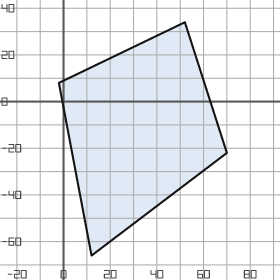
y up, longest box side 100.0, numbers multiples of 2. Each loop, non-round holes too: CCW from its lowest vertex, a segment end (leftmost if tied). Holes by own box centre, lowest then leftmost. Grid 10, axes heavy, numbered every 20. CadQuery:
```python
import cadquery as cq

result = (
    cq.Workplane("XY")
    .moveTo(12.0, -66.0)
    .lineTo(70.0, -22.0)
    .lineTo(52.0, 34.0)
    .lineTo(-2.0, 8.0)
    .close()
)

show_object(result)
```